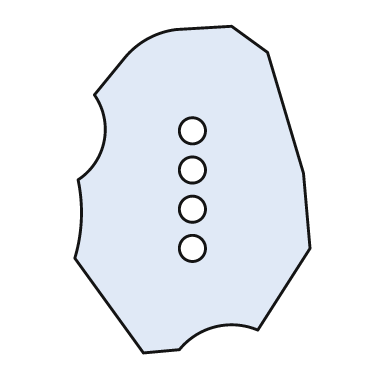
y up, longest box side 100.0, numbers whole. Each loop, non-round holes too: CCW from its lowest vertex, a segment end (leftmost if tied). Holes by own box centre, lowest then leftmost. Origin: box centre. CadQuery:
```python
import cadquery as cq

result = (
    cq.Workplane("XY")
    .moveTo(-15.0, -50.0)
    .lineTo(-4.0, -49.0)
    .threePointArc((7.0, -42.0), (20.0, -43.0))
    .lineTo(36.0, -18.0)
    .lineTo(34.0, 5.0)
    .lineTo(23.0, 42.0)
    .lineTo(12.0, 50.0)
    .lineTo(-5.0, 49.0)
    .threePointArc((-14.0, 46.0), (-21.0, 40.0))
    .lineTo(-30.0, 29.0)
    .threePointArc((-27.0, 15.0), (-35.0, 3.0))
    .threePointArc((-34.0, -9.0), (-36.0, -21.0))
    .close()
    .moveTo(0.0, -18.0)
    .circle(4.0)
    .moveTo(0.0, -6.0)
    .circle(4.0)
    .moveTo(0.0, 6.0)
    .circle(4.0)
    .moveTo(0.0, 18.0)
    .circle(4.0)
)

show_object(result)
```